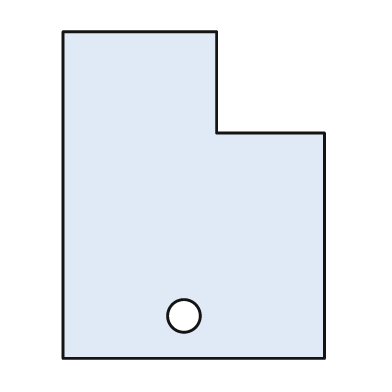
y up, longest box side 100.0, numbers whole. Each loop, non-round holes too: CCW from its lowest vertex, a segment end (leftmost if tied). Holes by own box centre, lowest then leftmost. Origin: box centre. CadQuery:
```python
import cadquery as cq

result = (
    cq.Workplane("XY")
    .moveTo(-40.0, -50.0)
    .lineTo(40.0, -50.0)
    .lineTo(40.0, 19.0)
    .lineTo(7.0, 19.0)
    .lineTo(7.0, 50.0)
    .lineTo(-40.0, 50.0)
    .close()
    .moveTo(-3.0, -37.0)
    .circle(5.0)
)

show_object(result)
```